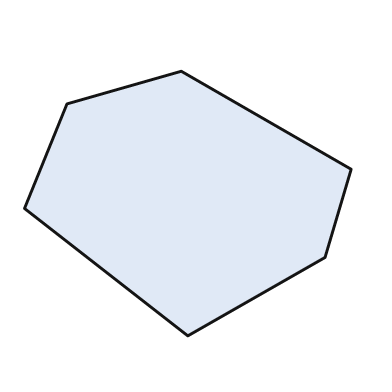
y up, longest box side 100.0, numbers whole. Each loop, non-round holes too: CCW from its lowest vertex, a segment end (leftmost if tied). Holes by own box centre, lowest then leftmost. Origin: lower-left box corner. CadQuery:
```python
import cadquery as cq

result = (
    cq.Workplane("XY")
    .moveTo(50.0, 0.0)
    .lineTo(92.0, 24.0)
    .lineTo(100.0, 51.0)
    .lineTo(48.0, 81.0)
    .lineTo(13.0, 71.0)
    .lineTo(0.0, 39.0)
    .close()
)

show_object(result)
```